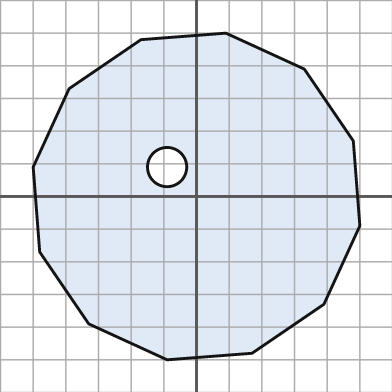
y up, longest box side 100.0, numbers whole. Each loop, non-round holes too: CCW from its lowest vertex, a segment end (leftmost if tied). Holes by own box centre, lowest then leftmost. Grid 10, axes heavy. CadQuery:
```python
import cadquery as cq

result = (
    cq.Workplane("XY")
    .moveTo(-9.0, -50.0)
    .lineTo(17.0, -48.0)
    .lineTo(39.0, -33.0)
    .lineTo(50.0, -9.0)
    .lineTo(48.0, 17.0)
    .lineTo(33.0, 39.0)
    .lineTo(9.0, 50.0)
    .lineTo(-17.0, 48.0)
    .lineTo(-39.0, 33.0)
    .lineTo(-50.0, 9.0)
    .lineTo(-48.0, -17.0)
    .lineTo(-33.0, -39.0)
    .close()
    .moveTo(-9.0, 9.0)
    .circle(6.0)
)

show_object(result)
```